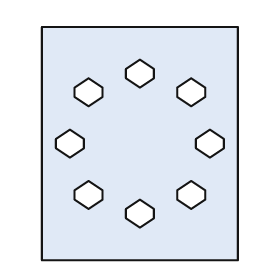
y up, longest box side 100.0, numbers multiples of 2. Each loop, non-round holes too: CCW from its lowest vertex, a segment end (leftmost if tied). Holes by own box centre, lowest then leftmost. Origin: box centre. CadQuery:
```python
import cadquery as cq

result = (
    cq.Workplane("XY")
    .moveTo(-42.0, -50.0)
    .lineTo(42.0, -50.0)
    .lineTo(42.0, 50.0)
    .lineTo(-42.0, 50.0)
    .close()
    .moveTo(0.0, -36.0)
    .lineTo(6.0, -32.0)
    .lineTo(6.0, -28.0)
    .lineTo(0.0, -24.0)
    .lineTo(-6.0, -28.0)
    .lineTo(-6.0, -32.0)
    .close()
    .moveTo(-22.0, -28.0)
    .lineTo(-16.0, -24.0)
    .lineTo(-16.0, -20.0)
    .lineTo(-22.0, -16.0)
    .lineTo(-28.0, -20.0)
    .lineTo(-28.0, -24.0)
    .close()
    .moveTo(22.0, -28.0)
    .lineTo(28.0, -24.0)
    .lineTo(28.0, -20.0)
    .lineTo(22.0, -16.0)
    .lineTo(16.0, -20.0)
    .lineTo(16.0, -24.0)
    .close()
    .moveTo(-30.0, -6.0)
    .lineTo(-24.0, -2.0)
    .lineTo(-24.0, 2.0)
    .lineTo(-30.0, 6.0)
    .lineTo(-36.0, 2.0)
    .lineTo(-36.0, -2.0)
    .close()
    .moveTo(30.0, -6.0)
    .lineTo(36.0, -2.0)
    .lineTo(36.0, 2.0)
    .lineTo(30.0, 6.0)
    .lineTo(24.0, 2.0)
    .lineTo(24.0, -2.0)
    .close()
    .moveTo(-22.0, 16.0)
    .lineTo(-16.0, 20.0)
    .lineTo(-16.0, 24.0)
    .lineTo(-22.0, 28.0)
    .lineTo(-28.0, 24.0)
    .lineTo(-28.0, 20.0)
    .close()
    .moveTo(22.0, 16.0)
    .lineTo(28.0, 20.0)
    .lineTo(28.0, 24.0)
    .lineTo(22.0, 28.0)
    .lineTo(16.0, 24.0)
    .lineTo(16.0, 20.0)
    .close()
    .moveTo(0.0, 24.0)
    .lineTo(6.0, 28.0)
    .lineTo(6.0, 32.0)
    .lineTo(0.0, 36.0)
    .lineTo(-6.0, 32.0)
    .lineTo(-6.0, 28.0)
    .close()
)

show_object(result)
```